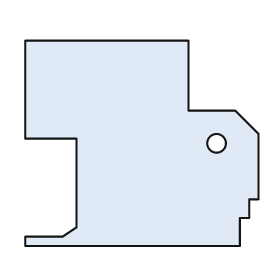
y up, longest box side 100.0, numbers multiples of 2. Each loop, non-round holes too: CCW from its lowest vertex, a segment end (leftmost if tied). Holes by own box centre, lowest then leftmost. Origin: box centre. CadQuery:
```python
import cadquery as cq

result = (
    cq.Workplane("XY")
    .moveTo(-50.0, -44.0)
    .lineTo(42.0, -44.0)
    .lineTo(42.0, -32.0)
    .lineTo(46.0, -32.0)
    .lineTo(46.0, -24.0)
    .lineTo(50.0, -24.0)
    .lineTo(50.0, 4.0)
    .lineTo(40.0, 14.0)
    .lineTo(20.0, 14.0)
    .lineTo(20.0, 44.0)
    .lineTo(-50.0, 44.0)
    .lineTo(-50.0, 2.0)
    .lineTo(-28.0, 2.0)
    .lineTo(-28.0, -36.0)
    .lineTo(-34.0, -40.0)
    .lineTo(-50.0, -40.0)
    .close()
    .moveTo(32.0, 0.0)
    .circle(4.0)
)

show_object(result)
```